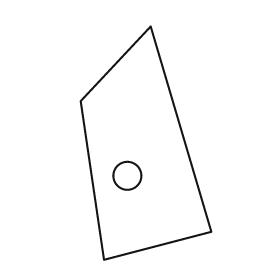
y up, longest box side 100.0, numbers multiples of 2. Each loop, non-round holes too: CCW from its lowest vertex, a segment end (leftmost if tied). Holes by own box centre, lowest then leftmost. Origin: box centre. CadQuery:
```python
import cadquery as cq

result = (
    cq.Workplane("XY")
    .moveTo(-18.0, -50.0)
    .lineTo(28.0, -38.0)
    .lineTo(2.0, 50.0)
    .lineTo(-28.0, 18.0)
    .close()
    .moveTo(-8.0, -14.0)
    .circle(6.0)
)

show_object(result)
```